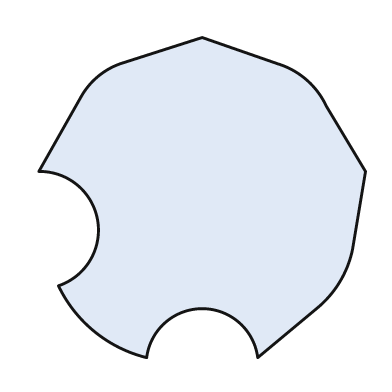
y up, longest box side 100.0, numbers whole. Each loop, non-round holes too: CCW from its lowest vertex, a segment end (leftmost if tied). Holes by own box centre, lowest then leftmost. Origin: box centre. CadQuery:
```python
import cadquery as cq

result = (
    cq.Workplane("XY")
    .moveTo(-17.0, -49.0)
    .threePointArc((0.0, -34.0), (17.0, -49.0))
    .lineTo(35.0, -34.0)
    .threePointArc((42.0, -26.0), (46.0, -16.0))
    .lineTo(50.0, 8.0)
    .lineTo(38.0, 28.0)
    .threePointArc((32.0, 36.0), (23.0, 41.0))
    .lineTo(0.0, 49.0)
    .lineTo(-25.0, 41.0)
    .threePointArc((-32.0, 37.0), (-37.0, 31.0))
    .lineTo(-50.0, 8.0)
    .threePointArc((-32.0, -7.0), (-44.0, -27.0))
    .threePointArc((-33.0, -41.0), (-17.0, -49.0))
    .close()
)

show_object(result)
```